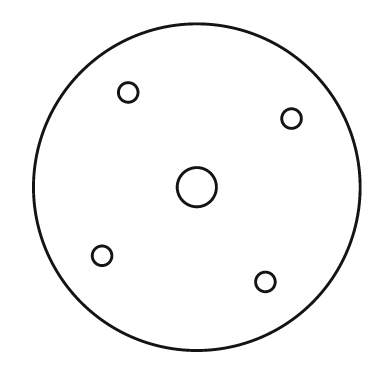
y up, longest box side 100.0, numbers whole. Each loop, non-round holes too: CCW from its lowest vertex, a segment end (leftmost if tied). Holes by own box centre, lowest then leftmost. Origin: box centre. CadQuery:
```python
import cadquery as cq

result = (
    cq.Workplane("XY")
    .moveTo(0.0, 0.0)
    .circle(50.0)
    .moveTo(21.0, -29.0)
    .circle(3.0)
    .moveTo(-29.0, -21.0)
    .circle(3.0)
    .moveTo(0.0, 0.0)
    .circle(6.0)
    .moveTo(29.0, 21.0)
    .circle(3.0)
    .moveTo(-21.0, 29.0)
    .circle(3.0)
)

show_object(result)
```